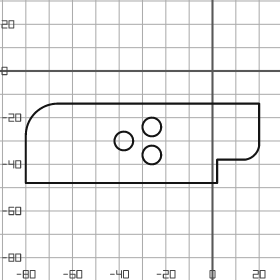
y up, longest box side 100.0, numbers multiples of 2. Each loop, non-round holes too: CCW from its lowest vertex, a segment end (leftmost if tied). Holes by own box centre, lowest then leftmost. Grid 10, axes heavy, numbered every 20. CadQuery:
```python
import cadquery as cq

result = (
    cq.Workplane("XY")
    .moveTo(-80.0, -48.0)
    .lineTo(2.0, -48.0)
    .lineTo(2.0, -38.0)
    .lineTo(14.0, -38.0)
    .threePointArc((18.0, -36.0), (20.0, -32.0))
    .lineTo(20.0, -14.0)
    .lineTo(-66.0, -14.0)
    .threePointArc((-76.0, -18.0), (-80.0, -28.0))
    .close()
    .moveTo(-26.0, -36.0)
    .circle(4.0)
    .moveTo(-38.0, -30.0)
    .circle(4.0)
    .moveTo(-26.0, -24.0)
    .circle(4.0)
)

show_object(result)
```